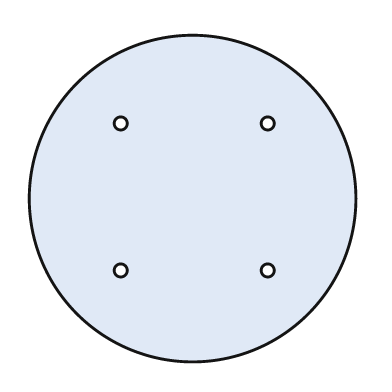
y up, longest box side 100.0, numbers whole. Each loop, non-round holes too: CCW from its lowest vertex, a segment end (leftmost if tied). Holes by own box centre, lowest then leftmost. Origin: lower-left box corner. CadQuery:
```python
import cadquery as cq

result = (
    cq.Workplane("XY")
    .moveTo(50.0, 50.0)
    .circle(50.0)
    .moveTo(28.0, 28.0)
    .circle(2.0)
    .moveTo(73.0, 28.0)
    .circle(2.0)
    .moveTo(28.0, 73.0)
    .circle(2.0)
    .moveTo(73.0, 73.0)
    .circle(2.0)
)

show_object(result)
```